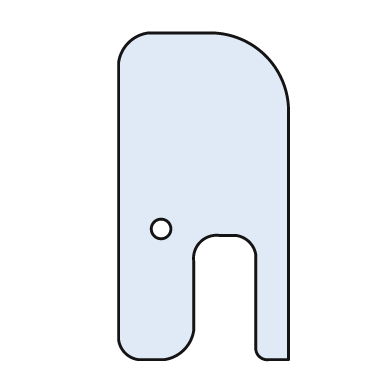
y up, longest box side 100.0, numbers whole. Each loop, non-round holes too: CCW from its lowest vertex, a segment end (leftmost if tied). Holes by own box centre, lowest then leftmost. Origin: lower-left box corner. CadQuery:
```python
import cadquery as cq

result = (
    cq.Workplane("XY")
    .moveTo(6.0, 0.0)
    .lineTo(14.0, 0.0)
    .threePointArc((20.0, 3.0), (23.0, 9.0))
    .lineTo(23.0, 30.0)
    .threePointArc((25.0, 36.0), (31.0, 38.0))
    .lineTo(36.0, 38.0)
    .threePointArc((40.0, 36.0), (42.0, 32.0))
    .lineTo(42.0, 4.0)
    .threePointArc((43.0, 1.0), (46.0, 0.0))
    .lineTo(52.0, 0.0)
    .lineTo(52.0, 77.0)
    .threePointArc((45.0, 93.0), (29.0, 100.0))
    .lineTo(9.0, 100.0)
    .threePointArc((3.0, 97.0), (0.0, 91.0))
    .lineTo(0.0, 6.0)
    .threePointArc((2.0, 2.0), (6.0, 0.0))
    .close()
    .moveTo(13.0, 40.0)
    .circle(3.0)
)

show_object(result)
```